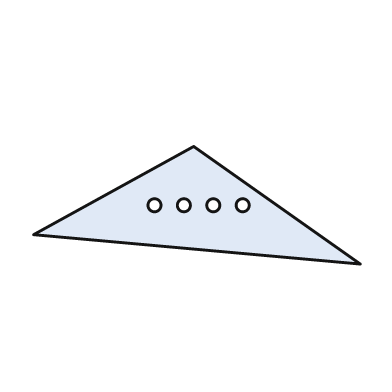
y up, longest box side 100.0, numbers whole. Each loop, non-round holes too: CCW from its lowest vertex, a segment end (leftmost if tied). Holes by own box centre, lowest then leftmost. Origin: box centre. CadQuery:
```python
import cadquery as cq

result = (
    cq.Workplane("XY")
    .moveTo(50.0, -18.0)
    .lineTo(-1.0, 18.0)
    .lineTo(-50.0, -9.0)
    .close()
    .moveTo(-13.0, 0.0)
    .circle(2.0)
    .moveTo(-4.0, 0.0)
    .circle(2.0)
    .moveTo(5.0, 0.0)
    .circle(2.0)
    .moveTo(14.0, 0.0)
    .circle(2.0)
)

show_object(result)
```